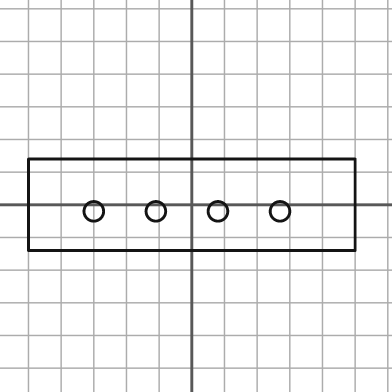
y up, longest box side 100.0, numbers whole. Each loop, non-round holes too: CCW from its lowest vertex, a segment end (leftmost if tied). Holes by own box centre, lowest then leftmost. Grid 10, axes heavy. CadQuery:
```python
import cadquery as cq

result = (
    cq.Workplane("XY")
    .moveTo(-50.0, -14.0)
    .lineTo(50.0, -14.0)
    .lineTo(50.0, 14.0)
    .lineTo(-50.0, 14.0)
    .close()
    .moveTo(-30.0, -2.0)
    .circle(3.0)
    .moveTo(-11.0, -2.0)
    .circle(3.0)
    .moveTo(8.0, -2.0)
    .circle(3.0)
    .moveTo(27.0, -2.0)
    .circle(3.0)
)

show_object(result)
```